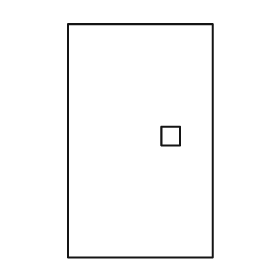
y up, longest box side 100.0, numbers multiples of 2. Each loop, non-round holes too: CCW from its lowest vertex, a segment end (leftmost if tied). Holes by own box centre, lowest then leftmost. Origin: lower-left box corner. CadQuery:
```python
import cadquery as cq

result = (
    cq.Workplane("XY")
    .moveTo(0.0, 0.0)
    .lineTo(62.0, 0.0)
    .lineTo(62.0, 100.0)
    .lineTo(0.0, 100.0)
    .close()
    .moveTo(40.0, 48.0)
    .lineTo(48.0, 48.0)
    .lineTo(48.0, 56.0)
    .lineTo(40.0, 56.0)
    .close()
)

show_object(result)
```